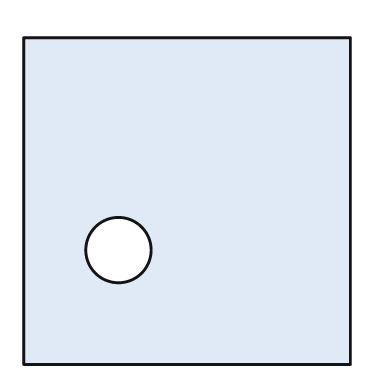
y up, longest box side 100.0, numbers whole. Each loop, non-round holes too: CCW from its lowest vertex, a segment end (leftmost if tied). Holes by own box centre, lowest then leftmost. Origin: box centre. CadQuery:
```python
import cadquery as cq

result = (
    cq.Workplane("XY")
    .moveTo(-50.0, -50.0)
    .lineTo(50.0, -50.0)
    .lineTo(50.0, 50.0)
    .lineTo(-50.0, 50.0)
    .close()
    .moveTo(-21.0, -15.0)
    .circle(10.0)
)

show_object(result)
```